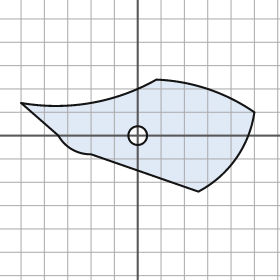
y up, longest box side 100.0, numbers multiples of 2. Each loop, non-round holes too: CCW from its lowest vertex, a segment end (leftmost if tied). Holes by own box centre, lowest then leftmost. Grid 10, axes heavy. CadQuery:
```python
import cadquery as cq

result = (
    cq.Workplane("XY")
    .moveTo(26.0, -24.0)
    .threePointArc((42.0, -10.0), (50.0, 10.0))
    .threePointArc((30.0, 20.0), (8.0, 24.0))
    .threePointArc((-20.0, 14.0), (-50.0, 14.0))
    .lineTo(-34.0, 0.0)
    .threePointArc((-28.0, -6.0), (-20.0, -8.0))
    .close()
    .moveTo(0.0, 0.0)
    .circle(4.0)
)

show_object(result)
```